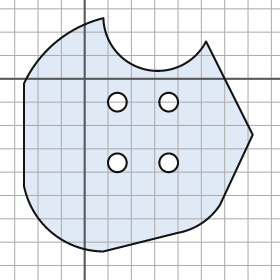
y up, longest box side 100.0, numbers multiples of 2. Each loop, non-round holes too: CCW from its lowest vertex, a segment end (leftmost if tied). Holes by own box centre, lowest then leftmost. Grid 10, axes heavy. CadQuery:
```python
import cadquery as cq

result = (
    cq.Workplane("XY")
    .moveTo(8.0, -74.0)
    .lineTo(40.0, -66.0)
    .threePointArc((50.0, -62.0), (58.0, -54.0))
    .lineTo(72.0, -24.0)
    .lineTo(52.0, 16.0)
    .threePointArc((26.0, 4.0), (8.0, 26.0))
    .threePointArc((-12.0, 16.0), (-26.0, -2.0))
    .lineTo(-26.0, -46.0)
    .threePointArc((-14.0, -66.0), (8.0, -74.0))
    .close()
    .moveTo(14.0, -36.0)
    .circle(4.0)
    .moveTo(36.0, -36.0)
    .circle(4.0)
    .moveTo(14.0, -10.0)
    .circle(4.0)
    .moveTo(36.0, -10.0)
    .circle(4.0)
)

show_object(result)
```